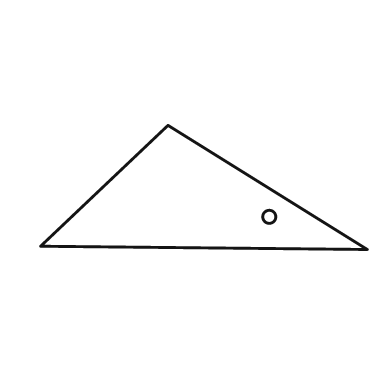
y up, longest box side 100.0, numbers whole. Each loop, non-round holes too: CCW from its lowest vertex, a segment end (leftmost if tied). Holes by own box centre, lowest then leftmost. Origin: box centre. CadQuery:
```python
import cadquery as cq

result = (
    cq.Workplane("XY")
    .moveTo(50.0, -19.0)
    .lineTo(-11.0, 19.0)
    .lineTo(-50.0, -18.0)
    .close()
    .moveTo(20.0, -9.0)
    .circle(2.0)
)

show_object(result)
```